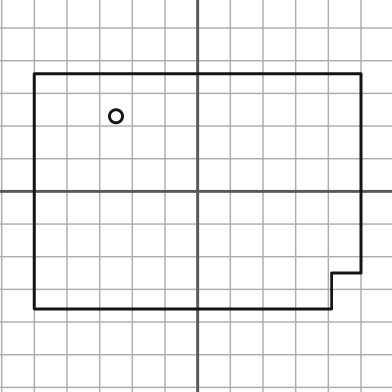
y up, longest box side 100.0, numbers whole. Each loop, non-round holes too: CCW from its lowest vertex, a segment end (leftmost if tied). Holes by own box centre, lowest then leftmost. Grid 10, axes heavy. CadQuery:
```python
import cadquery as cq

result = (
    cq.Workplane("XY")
    .moveTo(-50.0, -36.0)
    .lineTo(41.0, -36.0)
    .lineTo(41.0, -25.0)
    .lineTo(50.0, -25.0)
    .lineTo(50.0, 36.0)
    .lineTo(-50.0, 36.0)
    .close()
    .moveTo(-25.0, 23.0)
    .circle(2.0)
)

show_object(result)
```